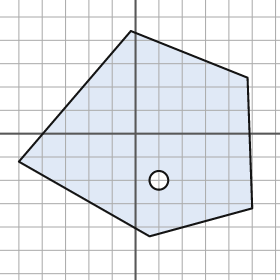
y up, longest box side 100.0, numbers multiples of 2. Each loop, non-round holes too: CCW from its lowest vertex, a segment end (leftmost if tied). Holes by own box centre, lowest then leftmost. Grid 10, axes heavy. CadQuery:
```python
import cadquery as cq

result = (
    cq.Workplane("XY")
    .moveTo(6.0, -44.0)
    .lineTo(50.0, -32.0)
    .lineTo(48.0, 24.0)
    .lineTo(-2.0, 44.0)
    .lineTo(-50.0, -12.0)
    .close()
    .moveTo(10.0, -20.0)
    .circle(4.0)
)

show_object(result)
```